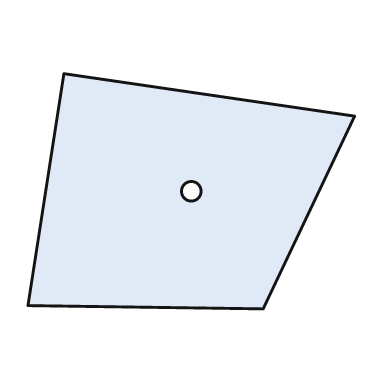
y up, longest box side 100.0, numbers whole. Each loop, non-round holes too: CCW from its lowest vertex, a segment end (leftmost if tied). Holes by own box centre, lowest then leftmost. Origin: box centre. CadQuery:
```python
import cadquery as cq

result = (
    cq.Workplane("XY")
    .moveTo(22.0, -36.0)
    .lineTo(50.0, 23.0)
    .lineTo(-39.0, 36.0)
    .lineTo(-50.0, -35.0)
    .close()
    .moveTo(0.0, 0.0)
    .circle(3.0)
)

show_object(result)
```